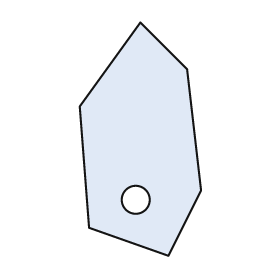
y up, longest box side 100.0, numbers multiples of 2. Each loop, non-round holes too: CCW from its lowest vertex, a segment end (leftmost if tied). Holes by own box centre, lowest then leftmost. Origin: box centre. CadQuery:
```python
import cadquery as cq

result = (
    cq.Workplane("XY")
    .moveTo(12.0, -50.0)
    .lineTo(26.0, -22.0)
    .lineTo(20.0, 30.0)
    .lineTo(0.0, 50.0)
    .lineTo(-26.0, 14.0)
    .lineTo(-22.0, -38.0)
    .close()
    .moveTo(-2.0, -26.0)
    .circle(6.0)
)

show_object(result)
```